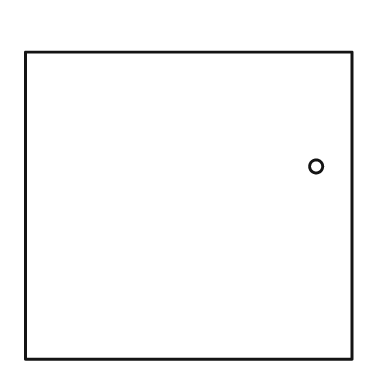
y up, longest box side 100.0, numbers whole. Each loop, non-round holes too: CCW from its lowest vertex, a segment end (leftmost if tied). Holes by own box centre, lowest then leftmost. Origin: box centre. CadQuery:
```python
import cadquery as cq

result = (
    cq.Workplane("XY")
    .moveTo(-50.0, -47.0)
    .lineTo(50.0, -47.0)
    .lineTo(50.0, 47.0)
    .lineTo(-50.0, 47.0)
    .close()
    .moveTo(39.0, 12.0)
    .circle(2.0)
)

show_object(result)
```